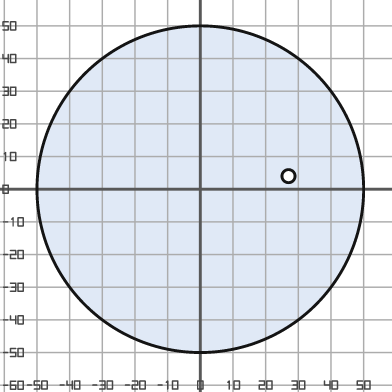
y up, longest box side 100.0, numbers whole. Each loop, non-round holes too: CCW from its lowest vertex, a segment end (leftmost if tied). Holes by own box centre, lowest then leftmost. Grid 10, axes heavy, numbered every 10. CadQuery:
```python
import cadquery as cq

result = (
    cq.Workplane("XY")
    .moveTo(0.0, 0.0)
    .circle(50.0)
    .moveTo(27.0, 4.0)
    .circle(2.0)
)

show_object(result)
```